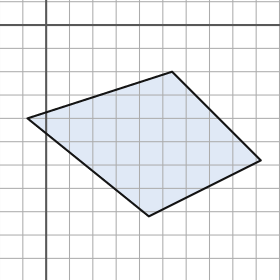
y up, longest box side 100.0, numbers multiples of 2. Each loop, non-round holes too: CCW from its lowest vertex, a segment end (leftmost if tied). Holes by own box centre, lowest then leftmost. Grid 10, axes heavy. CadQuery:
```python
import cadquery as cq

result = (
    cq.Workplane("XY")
    .moveTo(44.0, -82.0)
    .lineTo(92.0, -58.0)
    .lineTo(54.0, -20.0)
    .lineTo(-8.0, -40.0)
    .close()
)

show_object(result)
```